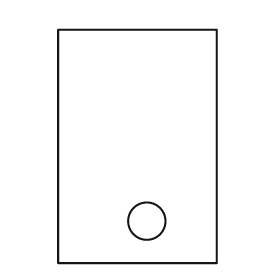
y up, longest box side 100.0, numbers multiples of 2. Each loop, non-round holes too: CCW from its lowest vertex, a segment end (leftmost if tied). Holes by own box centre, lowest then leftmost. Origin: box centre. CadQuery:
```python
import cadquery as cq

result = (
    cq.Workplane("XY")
    .moveTo(-34.0, -50.0)
    .lineTo(34.0, -50.0)
    .lineTo(34.0, 50.0)
    .lineTo(-34.0, 50.0)
    .close()
    .moveTo(4.0, -32.0)
    .circle(8.0)
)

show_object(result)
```